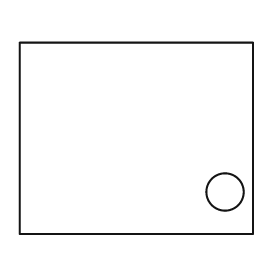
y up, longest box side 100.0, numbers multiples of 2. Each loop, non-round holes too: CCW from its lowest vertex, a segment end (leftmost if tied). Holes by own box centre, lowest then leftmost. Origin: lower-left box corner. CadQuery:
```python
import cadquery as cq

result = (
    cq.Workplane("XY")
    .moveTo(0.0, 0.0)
    .lineTo(100.0, 0.0)
    .lineTo(100.0, 82.0)
    .lineTo(0.0, 82.0)
    .close()
    .moveTo(88.0, 18.0)
    .circle(8.0)
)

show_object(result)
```